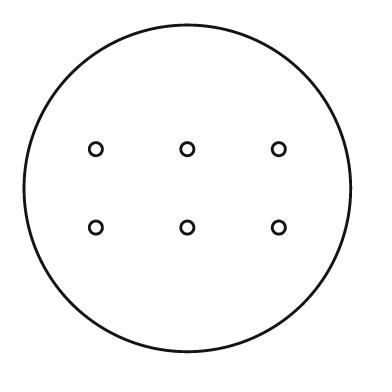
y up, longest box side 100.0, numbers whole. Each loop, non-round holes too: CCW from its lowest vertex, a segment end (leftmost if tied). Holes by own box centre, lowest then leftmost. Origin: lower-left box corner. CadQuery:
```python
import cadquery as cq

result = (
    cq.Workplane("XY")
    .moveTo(50.0, 50.0)
    .circle(50.0)
    .moveTo(22.0, 38.0)
    .circle(2.0)
    .moveTo(50.0, 38.0)
    .circle(2.0)
    .moveTo(78.0, 38.0)
    .circle(2.0)
    .moveTo(22.0, 62.0)
    .circle(2.0)
    .moveTo(50.0, 62.0)
    .circle(2.0)
    .moveTo(78.0, 62.0)
    .circle(2.0)
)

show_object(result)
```